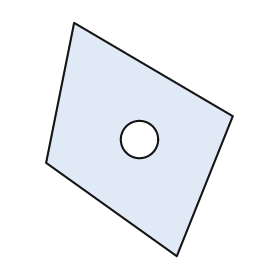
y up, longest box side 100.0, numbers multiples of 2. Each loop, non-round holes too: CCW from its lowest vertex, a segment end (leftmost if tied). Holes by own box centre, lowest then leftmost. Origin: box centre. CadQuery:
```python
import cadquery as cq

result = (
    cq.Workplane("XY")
    .moveTo(16.0, -50.0)
    .lineTo(40.0, 10.0)
    .lineTo(-28.0, 50.0)
    .lineTo(-40.0, -10.0)
    .close()
    .moveTo(0.0, 0.0)
    .circle(8.0)
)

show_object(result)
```